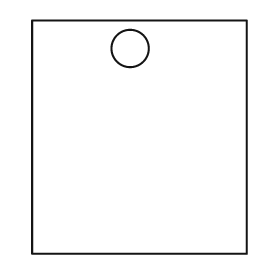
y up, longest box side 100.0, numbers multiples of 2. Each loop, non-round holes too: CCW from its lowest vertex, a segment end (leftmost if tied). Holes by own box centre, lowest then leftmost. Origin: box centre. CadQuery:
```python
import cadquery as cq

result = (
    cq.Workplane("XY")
    .moveTo(-46.0, -50.0)
    .lineTo(46.0, -50.0)
    .lineTo(46.0, 50.0)
    .lineTo(-46.0, 50.0)
    .close()
    .moveTo(-4.0, 38.0)
    .circle(8.0)
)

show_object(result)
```